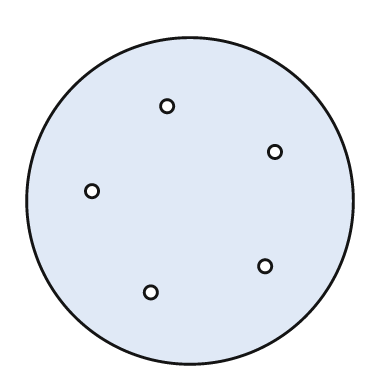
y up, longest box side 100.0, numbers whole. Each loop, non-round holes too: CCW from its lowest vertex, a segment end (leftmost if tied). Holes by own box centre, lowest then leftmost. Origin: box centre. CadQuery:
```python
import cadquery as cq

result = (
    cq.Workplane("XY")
    .moveTo(0.0, 0.0)
    .circle(50.0)
    .moveTo(-12.0, -28.0)
    .circle(2.0)
    .moveTo(23.0, -20.0)
    .circle(2.0)
    .moveTo(-30.0, 3.0)
    .circle(2.0)
    .moveTo(26.0, 15.0)
    .circle(2.0)
    .moveTo(-7.0, 29.0)
    .circle(2.0)
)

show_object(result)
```